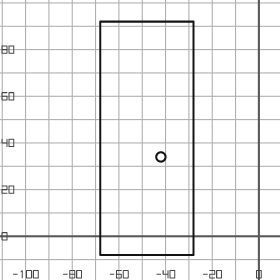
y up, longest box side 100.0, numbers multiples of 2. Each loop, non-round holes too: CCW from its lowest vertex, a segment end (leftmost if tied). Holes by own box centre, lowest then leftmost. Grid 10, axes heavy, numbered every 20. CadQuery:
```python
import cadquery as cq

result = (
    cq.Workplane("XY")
    .moveTo(-68.0, -8.0)
    .lineTo(-28.0, -8.0)
    .lineTo(-28.0, 92.0)
    .lineTo(-68.0, 92.0)
    .close()
    .moveTo(-42.0, 34.0)
    .circle(2.0)
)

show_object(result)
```